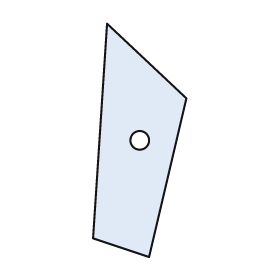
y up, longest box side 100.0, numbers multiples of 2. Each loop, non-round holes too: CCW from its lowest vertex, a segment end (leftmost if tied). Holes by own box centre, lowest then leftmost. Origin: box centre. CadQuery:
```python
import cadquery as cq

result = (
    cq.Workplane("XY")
    .moveTo(4.0, -50.0)
    .lineTo(20.0, 18.0)
    .lineTo(-14.0, 50.0)
    .lineTo(-20.0, -42.0)
    .close()
    .moveTo(0.0, 0.0)
    .circle(4.0)
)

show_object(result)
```